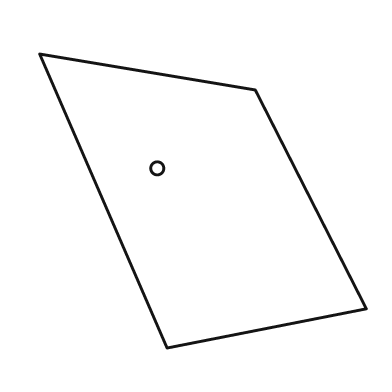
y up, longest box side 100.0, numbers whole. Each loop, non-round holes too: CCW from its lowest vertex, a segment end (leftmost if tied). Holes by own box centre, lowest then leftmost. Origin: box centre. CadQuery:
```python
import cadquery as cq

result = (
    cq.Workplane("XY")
    .moveTo(-11.0, -45.0)
    .lineTo(50.0, -33.0)
    .lineTo(16.0, 34.0)
    .lineTo(-50.0, 45.0)
    .close()
    .moveTo(-14.0, 10.0)
    .circle(2.0)
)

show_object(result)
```